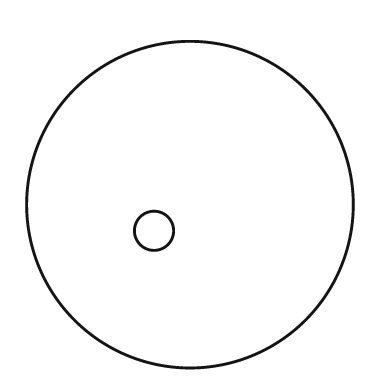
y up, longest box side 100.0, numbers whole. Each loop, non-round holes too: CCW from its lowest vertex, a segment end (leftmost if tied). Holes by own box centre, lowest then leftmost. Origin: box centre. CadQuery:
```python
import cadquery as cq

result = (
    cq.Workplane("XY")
    .moveTo(0.0, 0.0)
    .circle(50.0)
    .moveTo(-11.0, -8.0)
    .circle(6.0)
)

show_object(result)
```